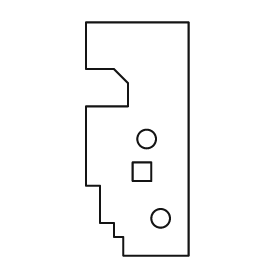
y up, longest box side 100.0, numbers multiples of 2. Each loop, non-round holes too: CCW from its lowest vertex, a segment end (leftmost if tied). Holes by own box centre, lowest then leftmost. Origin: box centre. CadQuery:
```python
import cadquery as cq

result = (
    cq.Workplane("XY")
    .moveTo(-6.0, -50.0)
    .lineTo(22.0, -50.0)
    .lineTo(22.0, 50.0)
    .lineTo(-22.0, 50.0)
    .lineTo(-22.0, 30.0)
    .lineTo(-10.0, 30.0)
    .lineTo(-4.0, 24.0)
    .lineTo(-4.0, 14.0)
    .lineTo(-22.0, 14.0)
    .lineTo(-22.0, -20.0)
    .lineTo(-16.0, -20.0)
    .lineTo(-16.0, -36.0)
    .lineTo(-10.0, -36.0)
    .lineTo(-10.0, -42.0)
    .lineTo(-6.0, -42.0)
    .close()
    .moveTo(10.0, -34.0)
    .circle(4.0)
    .moveTo(-2.0, -18.0)
    .lineTo(6.0, -18.0)
    .lineTo(6.0, -10.0)
    .lineTo(-2.0, -10.0)
    .close()
    .moveTo(4.0, 0.0)
    .circle(4.0)
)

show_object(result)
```